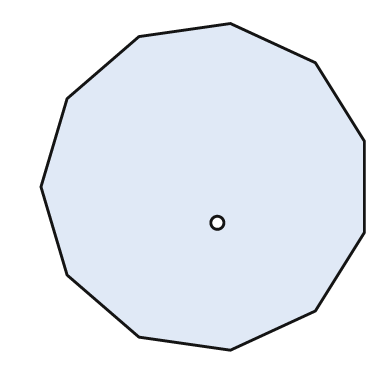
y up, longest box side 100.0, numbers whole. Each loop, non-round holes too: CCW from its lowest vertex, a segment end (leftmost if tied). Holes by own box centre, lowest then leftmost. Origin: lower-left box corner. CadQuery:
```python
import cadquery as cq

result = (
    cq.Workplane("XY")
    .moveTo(58.0, 0.0)
    .lineTo(84.0, 12.0)
    .lineTo(99.0, 36.0)
    .lineTo(99.0, 64.0)
    .lineTo(84.0, 88.0)
    .lineTo(58.0, 100.0)
    .lineTo(30.0, 96.0)
    .lineTo(8.0, 77.0)
    .lineTo(0.0, 50.0)
    .lineTo(8.0, 23.0)
    .lineTo(30.0, 4.0)
    .close()
    .moveTo(54.0, 39.0)
    .circle(2.0)
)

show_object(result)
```